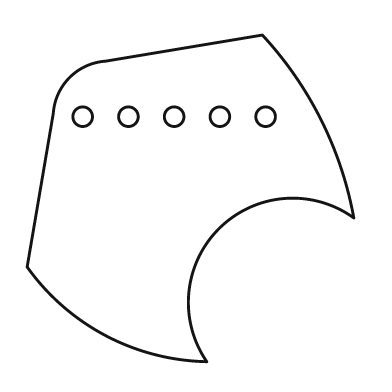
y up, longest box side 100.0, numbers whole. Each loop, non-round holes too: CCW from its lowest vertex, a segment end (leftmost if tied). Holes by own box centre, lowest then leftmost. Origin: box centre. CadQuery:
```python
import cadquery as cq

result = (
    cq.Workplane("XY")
    .moveTo(5.0, -50.0)
    .threePointArc((9.0, -9.0), (50.0, -6.0))
    .threePointArc((40.0, 24.0), (22.0, 50.0))
    .lineTo(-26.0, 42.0)
    .threePointArc((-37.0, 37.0), (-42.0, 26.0))
    .lineTo(-50.0, -21.0)
    .threePointArc((-26.0, -42.0), (5.0, -50.0))
    .close()
    .moveTo(-33.0, 25.0)
    .circle(3.0)
    .moveTo(-19.0, 25.0)
    .circle(3.0)
    .moveTo(-5.0, 25.0)
    .circle(3.0)
    .moveTo(9.0, 25.0)
    .circle(3.0)
    .moveTo(23.0, 25.0)
    .circle(3.0)
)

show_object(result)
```